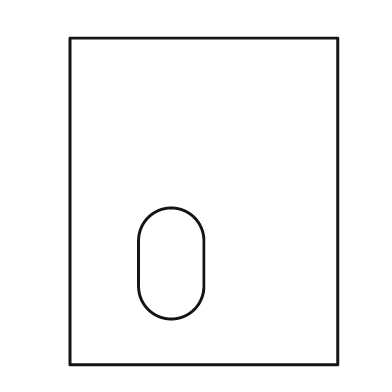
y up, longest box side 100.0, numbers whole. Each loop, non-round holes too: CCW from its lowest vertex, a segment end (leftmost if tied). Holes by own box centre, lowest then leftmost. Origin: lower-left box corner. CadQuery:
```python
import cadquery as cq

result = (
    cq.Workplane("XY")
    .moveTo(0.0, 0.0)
    .lineTo(82.0, 0.0)
    .lineTo(82.0, 100.0)
    .lineTo(0.0, 100.0)
    .close()
    .moveTo(21.0, 24.0)
    .threePointArc((31.0, 14.0), (41.0, 24.0))
    .lineTo(41.0, 38.0)
    .threePointArc((31.0, 48.0), (21.0, 38.0))
    .close()
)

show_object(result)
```